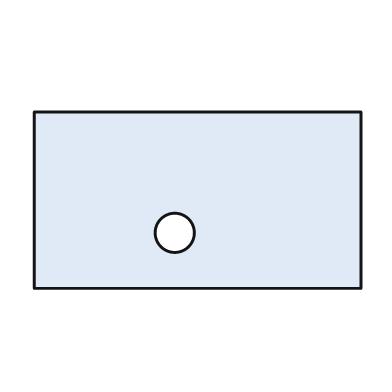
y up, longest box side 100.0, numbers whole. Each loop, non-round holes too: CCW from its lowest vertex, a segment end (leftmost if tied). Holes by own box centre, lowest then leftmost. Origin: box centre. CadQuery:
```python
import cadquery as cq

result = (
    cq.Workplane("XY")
    .moveTo(-50.0, -27.0)
    .lineTo(50.0, -27.0)
    .lineTo(50.0, 27.0)
    .lineTo(-50.0, 27.0)
    .close()
    .moveTo(-7.0, -10.0)
    .circle(6.0)
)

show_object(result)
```